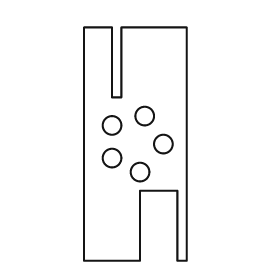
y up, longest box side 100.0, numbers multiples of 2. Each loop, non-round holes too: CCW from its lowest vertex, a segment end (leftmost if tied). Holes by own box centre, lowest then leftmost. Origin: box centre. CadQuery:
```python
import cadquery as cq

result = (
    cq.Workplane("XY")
    .moveTo(-22.0, -50.0)
    .lineTo(2.0, -50.0)
    .lineTo(2.0, -20.0)
    .lineTo(18.0, -20.0)
    .lineTo(18.0, -50.0)
    .lineTo(22.0, -50.0)
    .lineTo(22.0, 50.0)
    .lineTo(-6.0, 50.0)
    .lineTo(-6.0, 20.0)
    .lineTo(-10.0, 20.0)
    .lineTo(-10.0, 50.0)
    .lineTo(-22.0, 50.0)
    .close()
    .moveTo(2.0, -12.0)
    .circle(4.0)
    .moveTo(-10.0, -6.0)
    .circle(4.0)
    .moveTo(12.0, 0.0)
    .circle(4.0)
    .moveTo(-10.0, 8.0)
    .circle(4.0)
    .moveTo(4.0, 12.0)
    .circle(4.0)
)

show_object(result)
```